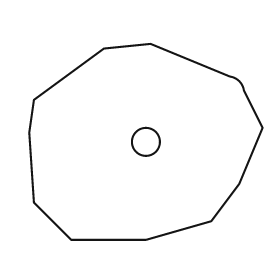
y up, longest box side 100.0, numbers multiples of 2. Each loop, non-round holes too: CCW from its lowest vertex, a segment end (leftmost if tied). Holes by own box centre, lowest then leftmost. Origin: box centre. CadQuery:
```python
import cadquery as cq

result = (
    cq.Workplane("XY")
    .moveTo(-32.0, -42.0)
    .lineTo(0.0, -42.0)
    .lineTo(28.0, -34.0)
    .lineTo(40.0, -18.0)
    .lineTo(50.0, 6.0)
    .lineTo(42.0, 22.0)
    .threePointArc((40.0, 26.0), (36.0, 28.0))
    .lineTo(2.0, 42.0)
    .lineTo(-18.0, 40.0)
    .lineTo(-48.0, 18.0)
    .lineTo(-50.0, 4.0)
    .lineTo(-48.0, -26.0)
    .close()
    .moveTo(0.0, 0.0)
    .circle(6.0)
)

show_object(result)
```